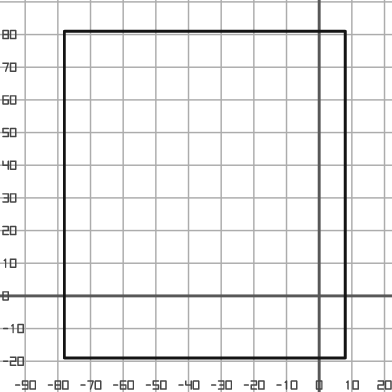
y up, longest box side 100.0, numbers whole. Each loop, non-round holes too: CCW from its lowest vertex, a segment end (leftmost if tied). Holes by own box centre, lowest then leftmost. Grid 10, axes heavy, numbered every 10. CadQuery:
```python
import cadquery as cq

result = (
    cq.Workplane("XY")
    .moveTo(-78.0, -19.0)
    .lineTo(8.0, -19.0)
    .lineTo(8.0, 81.0)
    .lineTo(-78.0, 81.0)
    .close()
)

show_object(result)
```